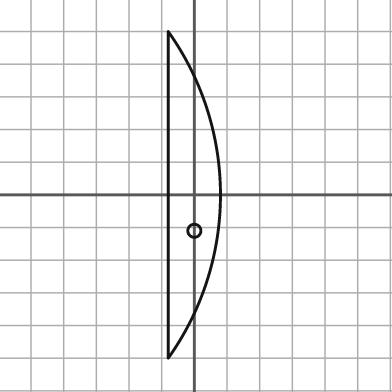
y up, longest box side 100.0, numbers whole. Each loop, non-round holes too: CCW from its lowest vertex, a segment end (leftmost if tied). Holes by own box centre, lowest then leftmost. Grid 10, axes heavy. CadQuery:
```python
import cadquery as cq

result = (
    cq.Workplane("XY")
    .moveTo(-8.0, -50.0)
    .threePointArc((8.0, 0.0), (-8.0, 50.0))
    .close()
    .moveTo(0.0, -11.0)
    .circle(2.0)
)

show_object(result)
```